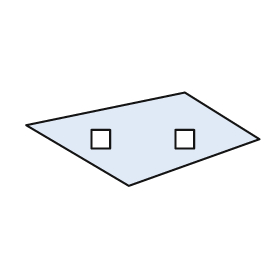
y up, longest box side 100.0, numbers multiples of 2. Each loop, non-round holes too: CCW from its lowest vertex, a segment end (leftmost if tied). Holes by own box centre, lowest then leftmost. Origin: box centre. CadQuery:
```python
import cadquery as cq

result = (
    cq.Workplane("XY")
    .moveTo(-6.0, -20.0)
    .lineTo(50.0, 0.0)
    .lineTo(18.0, 20.0)
    .lineTo(-50.0, 6.0)
    .close()
    .moveTo(-22.0, -4.0)
    .lineTo(-14.0, -4.0)
    .lineTo(-14.0, 4.0)
    .lineTo(-22.0, 4.0)
    .close()
    .moveTo(14.0, -4.0)
    .lineTo(22.0, -4.0)
    .lineTo(22.0, 4.0)
    .lineTo(14.0, 4.0)
    .close()
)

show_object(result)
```